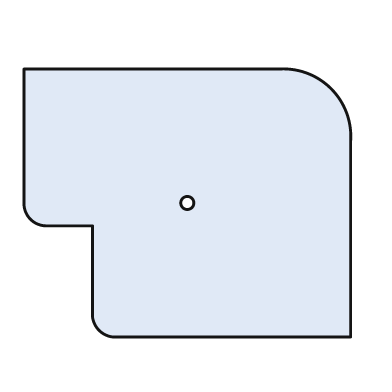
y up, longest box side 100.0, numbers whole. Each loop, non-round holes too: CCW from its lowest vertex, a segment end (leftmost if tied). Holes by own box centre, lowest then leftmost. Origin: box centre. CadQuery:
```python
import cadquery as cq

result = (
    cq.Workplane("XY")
    .moveTo(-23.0, -41.0)
    .lineTo(50.0, -41.0)
    .lineTo(50.0, 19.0)
    .threePointArc((44.0, 35.0), (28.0, 41.0))
    .lineTo(-50.0, 41.0)
    .lineTo(-50.0, 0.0)
    .threePointArc((-48.0, -5.0), (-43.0, -7.0))
    .lineTo(-29.0, -7.0)
    .lineTo(-29.0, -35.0)
    .threePointArc((-27.0, -39.0), (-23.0, -41.0))
    .close()
    .moveTo(0.0, 0.0)
    .circle(2.0)
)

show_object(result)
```